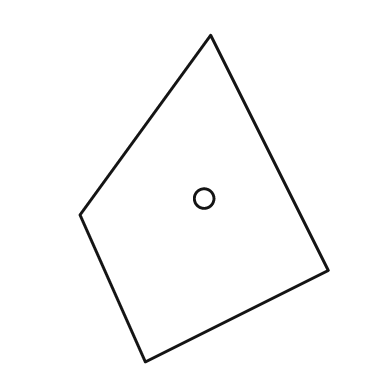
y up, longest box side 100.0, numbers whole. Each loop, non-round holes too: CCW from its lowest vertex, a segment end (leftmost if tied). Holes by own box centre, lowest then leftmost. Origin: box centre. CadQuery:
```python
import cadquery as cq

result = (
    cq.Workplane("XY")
    .moveTo(-18.0, -50.0)
    .lineTo(38.0, -22.0)
    .lineTo(2.0, 50.0)
    .lineTo(-38.0, -5.0)
    .close()
    .moveTo(0.0, 0.0)
    .circle(3.0)
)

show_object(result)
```